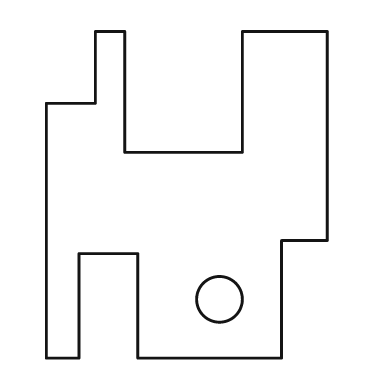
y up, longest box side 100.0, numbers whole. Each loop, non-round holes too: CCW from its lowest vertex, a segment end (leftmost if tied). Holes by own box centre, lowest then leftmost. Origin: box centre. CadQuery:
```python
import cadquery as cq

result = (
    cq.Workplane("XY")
    .moveTo(-43.0, -50.0)
    .lineTo(-33.0, -50.0)
    .lineTo(-33.0, -18.0)
    .lineTo(-15.0, -18.0)
    .lineTo(-15.0, -50.0)
    .lineTo(29.0, -50.0)
    .lineTo(29.0, -14.0)
    .lineTo(43.0, -14.0)
    .lineTo(43.0, 50.0)
    .lineTo(17.0, 50.0)
    .lineTo(17.0, 13.0)
    .lineTo(-19.0, 13.0)
    .lineTo(-19.0, 50.0)
    .lineTo(-28.0, 50.0)
    .lineTo(-28.0, 28.0)
    .lineTo(-43.0, 28.0)
    .close()
    .moveTo(10.0, -32.0)
    .circle(7.0)
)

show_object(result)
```